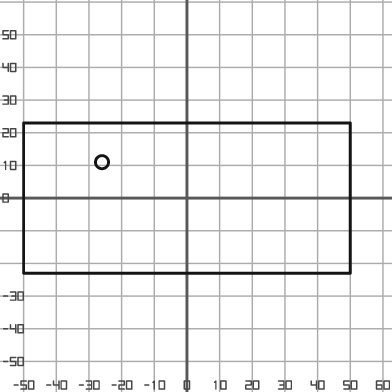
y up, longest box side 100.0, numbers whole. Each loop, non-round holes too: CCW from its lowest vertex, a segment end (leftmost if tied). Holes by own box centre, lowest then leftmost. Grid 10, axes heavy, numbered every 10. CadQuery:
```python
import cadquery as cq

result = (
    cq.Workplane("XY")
    .moveTo(-50.0, -23.0)
    .lineTo(50.0, -23.0)
    .lineTo(50.0, 23.0)
    .lineTo(-50.0, 23.0)
    .close()
    .moveTo(-26.0, 11.0)
    .circle(2.0)
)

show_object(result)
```